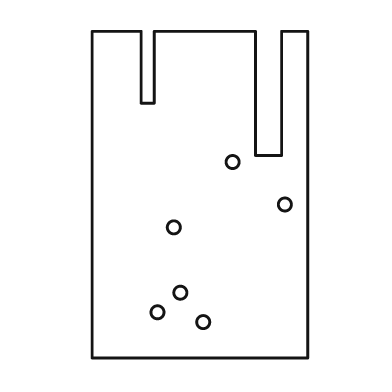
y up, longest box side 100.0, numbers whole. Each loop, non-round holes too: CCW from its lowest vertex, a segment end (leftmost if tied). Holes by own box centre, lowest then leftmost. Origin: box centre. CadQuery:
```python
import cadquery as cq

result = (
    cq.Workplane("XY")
    .moveTo(-33.0, -50.0)
    .lineTo(33.0, -50.0)
    .lineTo(33.0, 50.0)
    .lineTo(25.0, 50.0)
    .lineTo(25.0, 12.0)
    .lineTo(17.0, 12.0)
    .lineTo(17.0, 50.0)
    .lineTo(-14.0, 50.0)
    .lineTo(-14.0, 28.0)
    .lineTo(-18.0, 28.0)
    .lineTo(-18.0, 50.0)
    .lineTo(-33.0, 50.0)
    .close()
    .moveTo(1.0, -39.0)
    .circle(2.0)
    .moveTo(-13.0, -36.0)
    .circle(2.0)
    .moveTo(-6.0, -30.0)
    .circle(2.0)
    .moveTo(-8.0, -10.0)
    .circle(2.0)
    .moveTo(26.0, -3.0)
    .circle(2.0)
    .moveTo(10.0, 10.0)
    .circle(2.0)
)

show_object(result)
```